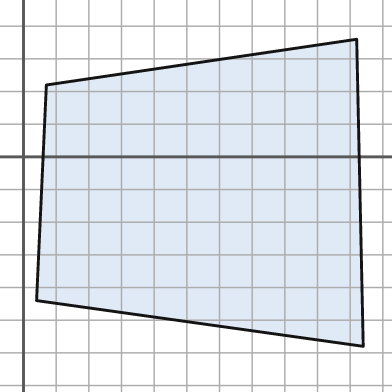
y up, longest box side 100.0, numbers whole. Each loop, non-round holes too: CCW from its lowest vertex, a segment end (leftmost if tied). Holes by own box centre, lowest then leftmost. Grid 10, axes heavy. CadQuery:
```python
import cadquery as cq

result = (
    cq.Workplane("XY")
    .moveTo(104.0, -58.0)
    .lineTo(102.0, 36.0)
    .lineTo(7.0, 22.0)
    .lineTo(4.0, -44.0)
    .close()
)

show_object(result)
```